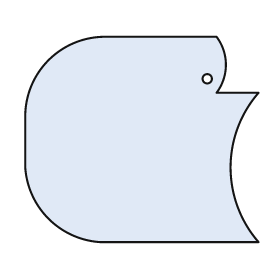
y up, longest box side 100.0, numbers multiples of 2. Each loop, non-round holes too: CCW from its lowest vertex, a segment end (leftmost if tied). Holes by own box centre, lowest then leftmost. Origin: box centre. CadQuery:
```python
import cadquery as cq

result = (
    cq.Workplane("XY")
    .moveTo(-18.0, -44.0)
    .lineTo(50.0, -44.0)
    .threePointArc((38.0, -12.0), (50.0, 20.0))
    .lineTo(32.0, 20.0)
    .threePointArc((36.0, 32.0), (32.0, 44.0))
    .lineTo(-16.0, 44.0)
    .threePointArc((-40.0, 34.0), (-50.0, 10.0))
    .lineTo(-50.0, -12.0)
    .threePointArc((-40.0, -34.0), (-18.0, -44.0))
    .close()
    .moveTo(28.0, 26.0)
    .circle(2.0)
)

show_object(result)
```